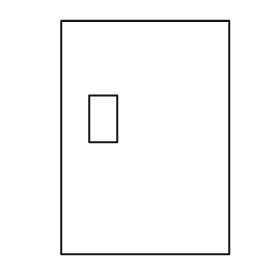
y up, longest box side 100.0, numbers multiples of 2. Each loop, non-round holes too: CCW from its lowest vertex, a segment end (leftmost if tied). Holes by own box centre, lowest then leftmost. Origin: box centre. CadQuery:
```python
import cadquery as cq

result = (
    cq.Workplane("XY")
    .moveTo(-36.0, -50.0)
    .lineTo(36.0, -50.0)
    .lineTo(36.0, 50.0)
    .lineTo(-36.0, 50.0)
    .close()
    .moveTo(-24.0, -2.0)
    .lineTo(-12.0, -2.0)
    .lineTo(-12.0, 18.0)
    .lineTo(-24.0, 18.0)
    .close()
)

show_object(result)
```